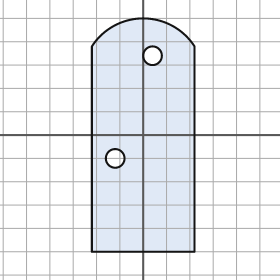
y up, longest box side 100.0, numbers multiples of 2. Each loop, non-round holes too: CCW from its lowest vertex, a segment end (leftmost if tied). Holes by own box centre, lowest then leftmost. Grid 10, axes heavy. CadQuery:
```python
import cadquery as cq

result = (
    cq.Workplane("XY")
    .moveTo(-22.0, -50.0)
    .lineTo(22.0, -50.0)
    .lineTo(22.0, 38.0)
    .threePointArc((0.0, 50.0), (-22.0, 38.0))
    .close()
    .moveTo(-12.0, -10.0)
    .circle(4.0)
    .moveTo(4.0, 34.0)
    .circle(4.0)
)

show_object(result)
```